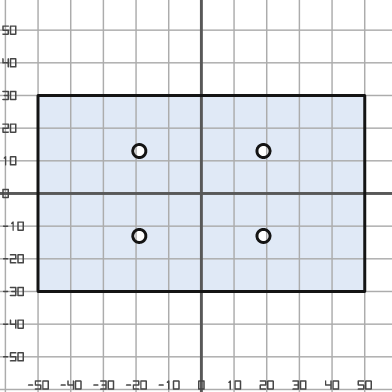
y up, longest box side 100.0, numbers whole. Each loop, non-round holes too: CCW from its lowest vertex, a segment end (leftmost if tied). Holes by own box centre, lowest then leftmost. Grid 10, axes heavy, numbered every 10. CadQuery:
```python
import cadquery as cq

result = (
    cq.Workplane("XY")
    .moveTo(-50.0, -30.0)
    .lineTo(50.0, -30.0)
    .lineTo(50.0, 30.0)
    .lineTo(-50.0, 30.0)
    .close()
    .moveTo(-19.0, -13.0)
    .circle(2.0)
    .moveTo(19.0, -13.0)
    .circle(2.0)
    .moveTo(-19.0, 13.0)
    .circle(2.0)
    .moveTo(19.0, 13.0)
    .circle(2.0)
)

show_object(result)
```